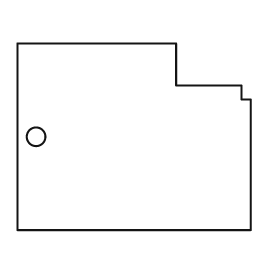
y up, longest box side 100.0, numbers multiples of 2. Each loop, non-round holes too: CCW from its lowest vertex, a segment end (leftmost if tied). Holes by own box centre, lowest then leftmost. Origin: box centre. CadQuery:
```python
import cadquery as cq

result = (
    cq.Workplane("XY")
    .moveTo(-50.0, -40.0)
    .lineTo(50.0, -40.0)
    .lineTo(50.0, 16.0)
    .lineTo(46.0, 16.0)
    .lineTo(46.0, 22.0)
    .lineTo(18.0, 22.0)
    .lineTo(18.0, 40.0)
    .lineTo(-50.0, 40.0)
    .close()
    .moveTo(-42.0, 0.0)
    .circle(4.0)
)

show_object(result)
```